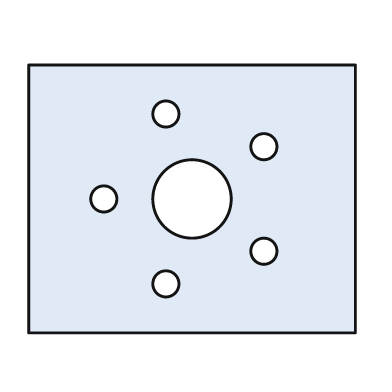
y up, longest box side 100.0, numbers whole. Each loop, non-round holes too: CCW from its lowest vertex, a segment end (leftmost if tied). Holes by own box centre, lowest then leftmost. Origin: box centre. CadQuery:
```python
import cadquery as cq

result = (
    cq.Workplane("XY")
    .moveTo(-50.0, -41.0)
    .lineTo(50.0, -41.0)
    .lineTo(50.0, 41.0)
    .lineTo(-50.0, 41.0)
    .close()
    .moveTo(-8.0, -26.0)
    .circle(4.0)
    .moveTo(22.0, -16.0)
    .circle(4.0)
    .moveTo(-27.0, 0.0)
    .circle(4.0)
    .moveTo(0.0, 0.0)
    .circle(12.0)
    .moveTo(22.0, 16.0)
    .circle(4.0)
    .moveTo(-8.0, 26.0)
    .circle(4.0)
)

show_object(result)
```